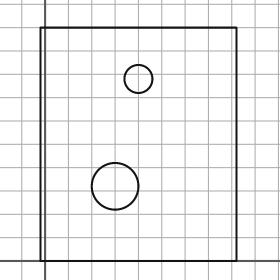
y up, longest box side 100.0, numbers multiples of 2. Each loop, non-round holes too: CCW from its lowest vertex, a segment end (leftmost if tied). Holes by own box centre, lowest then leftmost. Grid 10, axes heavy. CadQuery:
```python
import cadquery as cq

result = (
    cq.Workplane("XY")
    .moveTo(-2.0, 0.0)
    .lineTo(82.0, 0.0)
    .lineTo(82.0, 100.0)
    .lineTo(-2.0, 100.0)
    .close()
    .moveTo(30.0, 32.0)
    .circle(10.0)
    .moveTo(40.0, 78.0)
    .circle(6.0)
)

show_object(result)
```